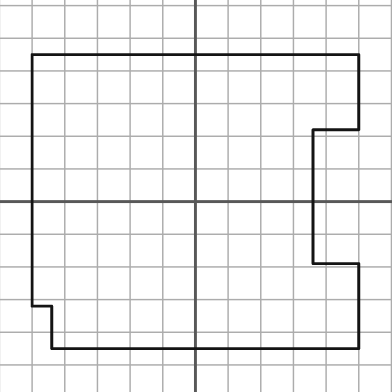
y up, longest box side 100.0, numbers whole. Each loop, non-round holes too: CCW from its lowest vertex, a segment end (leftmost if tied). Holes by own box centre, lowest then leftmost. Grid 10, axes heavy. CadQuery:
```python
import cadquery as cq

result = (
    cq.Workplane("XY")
    .moveTo(-44.0, -45.0)
    .lineTo(50.0, -45.0)
    .lineTo(50.0, -19.0)
    .lineTo(36.0, -19.0)
    .lineTo(36.0, 22.0)
    .lineTo(50.0, 22.0)
    .lineTo(50.0, 45.0)
    .lineTo(-50.0, 45.0)
    .lineTo(-50.0, -32.0)
    .lineTo(-44.0, -32.0)
    .close()
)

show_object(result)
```